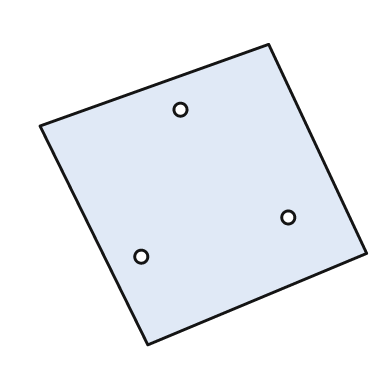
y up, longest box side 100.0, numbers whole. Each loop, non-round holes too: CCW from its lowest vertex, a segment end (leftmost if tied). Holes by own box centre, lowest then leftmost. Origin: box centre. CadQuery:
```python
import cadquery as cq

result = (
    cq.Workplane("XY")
    .moveTo(-17.0, -46.0)
    .lineTo(50.0, -18.0)
    .lineTo(20.0, 46.0)
    .lineTo(-50.0, 21.0)
    .close()
    .moveTo(-19.0, -19.0)
    .circle(2.0)
    .moveTo(26.0, -7.0)
    .circle(2.0)
    .moveTo(-7.0, 26.0)
    .circle(2.0)
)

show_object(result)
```